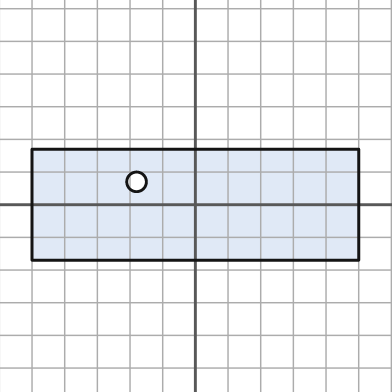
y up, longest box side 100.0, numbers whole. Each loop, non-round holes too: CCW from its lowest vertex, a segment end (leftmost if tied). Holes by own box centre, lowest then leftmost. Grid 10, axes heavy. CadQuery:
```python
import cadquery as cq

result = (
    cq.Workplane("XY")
    .moveTo(-50.0, -17.0)
    .lineTo(50.0, -17.0)
    .lineTo(50.0, 17.0)
    .lineTo(-50.0, 17.0)
    .close()
    .moveTo(-18.0, 7.0)
    .circle(3.0)
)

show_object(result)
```